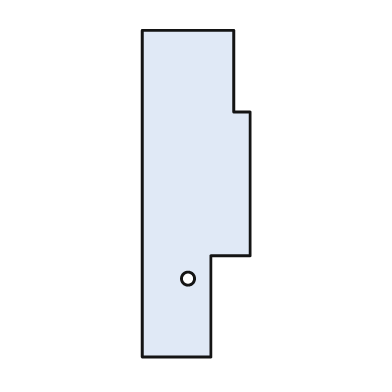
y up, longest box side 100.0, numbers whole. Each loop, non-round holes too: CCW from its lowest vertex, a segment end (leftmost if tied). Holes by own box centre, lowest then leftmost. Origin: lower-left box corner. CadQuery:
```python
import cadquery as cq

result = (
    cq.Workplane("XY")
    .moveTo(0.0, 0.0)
    .lineTo(21.0, 0.0)
    .lineTo(21.0, 31.0)
    .lineTo(33.0, 31.0)
    .lineTo(33.0, 75.0)
    .lineTo(28.0, 75.0)
    .lineTo(28.0, 100.0)
    .lineTo(0.0, 100.0)
    .close()
    .moveTo(14.0, 24.0)
    .circle(2.0)
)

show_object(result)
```